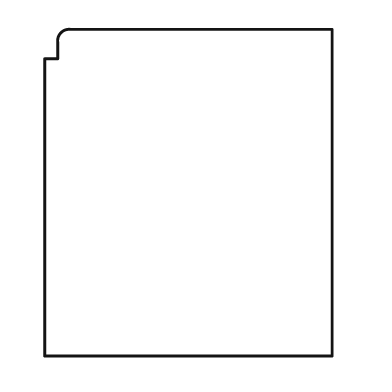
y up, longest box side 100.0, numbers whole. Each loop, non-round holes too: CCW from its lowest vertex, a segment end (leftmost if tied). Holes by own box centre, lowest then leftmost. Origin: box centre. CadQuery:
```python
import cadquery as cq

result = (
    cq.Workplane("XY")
    .moveTo(-44.0, -50.0)
    .lineTo(44.0, -50.0)
    .lineTo(44.0, 50.0)
    .lineTo(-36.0, 50.0)
    .threePointArc((-39.0, 49.0), (-40.0, 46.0))
    .lineTo(-40.0, 41.0)
    .lineTo(-44.0, 41.0)
    .close()
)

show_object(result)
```